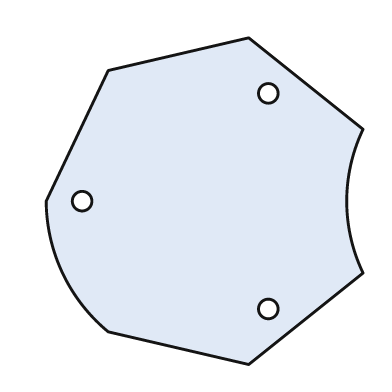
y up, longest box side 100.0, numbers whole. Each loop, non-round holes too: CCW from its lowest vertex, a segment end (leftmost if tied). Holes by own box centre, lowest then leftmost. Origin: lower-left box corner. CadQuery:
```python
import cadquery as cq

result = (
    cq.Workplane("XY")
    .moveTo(62.0, 0.0)
    .lineTo(97.0, 28.0)
    .threePointArc((92.0, 50.0), (97.0, 72.0))
    .lineTo(62.0, 100.0)
    .lineTo(19.0, 90.0)
    .lineTo(0.0, 50.0)
    .threePointArc((5.0, 28.0), (19.0, 10.0))
    .close()
    .moveTo(68.0, 17.0)
    .circle(3.0)
    .moveTo(11.0, 50.0)
    .circle(3.0)
    .moveTo(68.0, 83.0)
    .circle(3.0)
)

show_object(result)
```